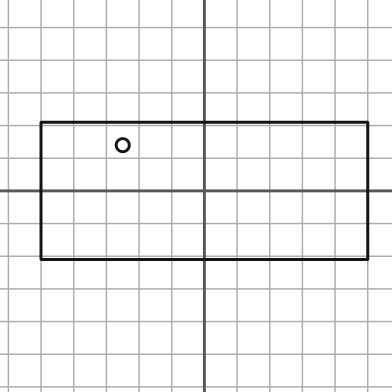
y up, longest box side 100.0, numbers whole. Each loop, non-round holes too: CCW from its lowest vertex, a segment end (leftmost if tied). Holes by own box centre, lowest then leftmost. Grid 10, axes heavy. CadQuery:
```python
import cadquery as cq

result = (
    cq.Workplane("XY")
    .moveTo(-50.0, -21.0)
    .lineTo(50.0, -21.0)
    .lineTo(50.0, 21.0)
    .lineTo(-50.0, 21.0)
    .close()
    .moveTo(-25.0, 14.0)
    .circle(2.0)
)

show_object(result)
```